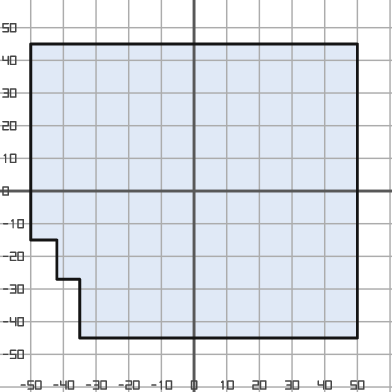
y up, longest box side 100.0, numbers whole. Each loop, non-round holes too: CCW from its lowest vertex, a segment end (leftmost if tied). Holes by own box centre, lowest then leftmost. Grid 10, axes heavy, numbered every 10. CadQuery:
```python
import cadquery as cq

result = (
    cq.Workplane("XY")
    .moveTo(-35.0, -45.0)
    .lineTo(50.0, -45.0)
    .lineTo(50.0, 45.0)
    .lineTo(-50.0, 45.0)
    .lineTo(-50.0, -15.0)
    .lineTo(-42.0, -15.0)
    .lineTo(-42.0, -27.0)
    .lineTo(-35.0, -27.0)
    .close()
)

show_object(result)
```